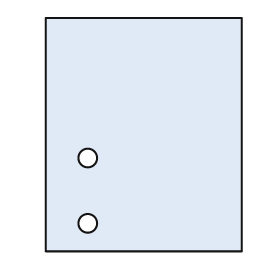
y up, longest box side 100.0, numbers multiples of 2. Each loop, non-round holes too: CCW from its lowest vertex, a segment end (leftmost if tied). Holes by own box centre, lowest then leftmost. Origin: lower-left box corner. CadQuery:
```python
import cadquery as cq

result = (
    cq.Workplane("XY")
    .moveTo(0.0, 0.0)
    .lineTo(84.0, 0.0)
    .lineTo(84.0, 100.0)
    .lineTo(0.0, 100.0)
    .close()
    .moveTo(18.0, 12.0)
    .circle(4.0)
    .moveTo(18.0, 40.0)
    .circle(4.0)
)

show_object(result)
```